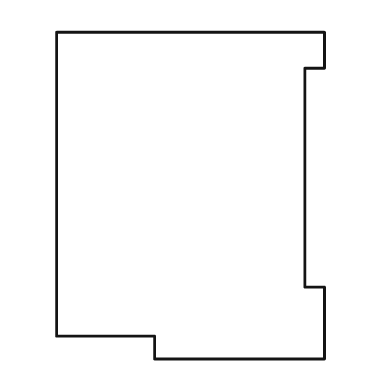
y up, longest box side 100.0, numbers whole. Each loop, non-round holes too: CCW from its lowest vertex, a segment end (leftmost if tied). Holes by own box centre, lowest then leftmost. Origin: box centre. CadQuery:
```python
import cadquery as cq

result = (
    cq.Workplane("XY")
    .moveTo(-11.0, -50.0)
    .lineTo(41.0, -50.0)
    .lineTo(41.0, -28.0)
    .lineTo(35.0, -28.0)
    .lineTo(35.0, 39.0)
    .lineTo(41.0, 39.0)
    .lineTo(41.0, 50.0)
    .lineTo(-41.0, 50.0)
    .lineTo(-41.0, -43.0)
    .lineTo(-11.0, -43.0)
    .close()
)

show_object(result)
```